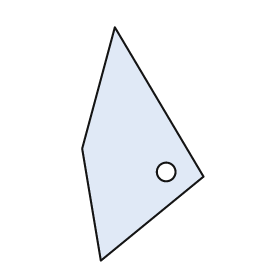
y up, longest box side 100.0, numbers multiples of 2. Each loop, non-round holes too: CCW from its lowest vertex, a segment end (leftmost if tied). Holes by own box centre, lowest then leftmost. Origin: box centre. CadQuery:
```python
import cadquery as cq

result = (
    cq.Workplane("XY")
    .moveTo(-18.0, -50.0)
    .lineTo(26.0, -14.0)
    .lineTo(-12.0, 50.0)
    .lineTo(-26.0, -2.0)
    .close()
    .moveTo(10.0, -12.0)
    .circle(4.0)
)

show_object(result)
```